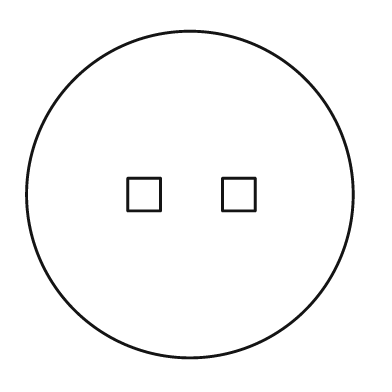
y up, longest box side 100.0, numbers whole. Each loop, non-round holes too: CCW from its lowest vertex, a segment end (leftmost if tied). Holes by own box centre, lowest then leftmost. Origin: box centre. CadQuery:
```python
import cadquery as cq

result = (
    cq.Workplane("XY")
    .moveTo(0.0, 0.0)
    .circle(50.0)
    .moveTo(-19.0, -5.0)
    .lineTo(-9.0, -5.0)
    .lineTo(-9.0, 5.0)
    .lineTo(-19.0, 5.0)
    .close()
    .moveTo(10.0, -5.0)
    .lineTo(20.0, -5.0)
    .lineTo(20.0, 5.0)
    .lineTo(10.0, 5.0)
    .close()
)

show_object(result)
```